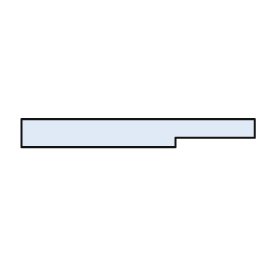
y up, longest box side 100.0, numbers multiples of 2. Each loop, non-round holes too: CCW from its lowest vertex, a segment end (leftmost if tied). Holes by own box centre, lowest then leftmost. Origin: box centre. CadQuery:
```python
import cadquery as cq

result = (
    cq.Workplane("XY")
    .moveTo(-50.0, -6.0)
    .lineTo(16.0, -6.0)
    .lineTo(16.0, -2.0)
    .lineTo(50.0, -2.0)
    .lineTo(50.0, 6.0)
    .lineTo(-50.0, 6.0)
    .close()
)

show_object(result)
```